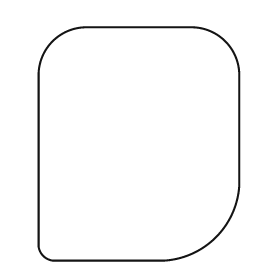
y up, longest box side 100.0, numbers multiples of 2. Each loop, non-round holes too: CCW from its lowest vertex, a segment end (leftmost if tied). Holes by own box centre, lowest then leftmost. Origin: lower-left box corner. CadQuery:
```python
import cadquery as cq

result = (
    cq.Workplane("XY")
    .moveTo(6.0, 0.0)
    .lineTo(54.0, 0.0)
    .threePointArc((76.0, 10.0), (86.0, 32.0))
    .lineTo(86.0, 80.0)
    .threePointArc((80.0, 94.0), (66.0, 100.0))
    .lineTo(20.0, 100.0)
    .threePointArc((6.0, 94.0), (0.0, 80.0))
    .lineTo(0.0, 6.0)
    .threePointArc((2.0, 2.0), (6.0, 0.0))
    .close()
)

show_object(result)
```